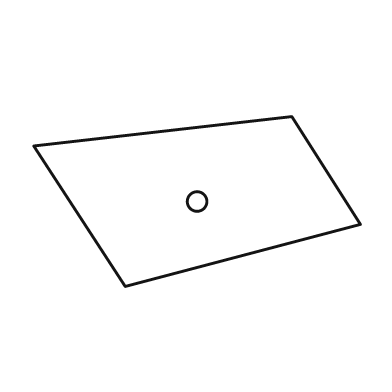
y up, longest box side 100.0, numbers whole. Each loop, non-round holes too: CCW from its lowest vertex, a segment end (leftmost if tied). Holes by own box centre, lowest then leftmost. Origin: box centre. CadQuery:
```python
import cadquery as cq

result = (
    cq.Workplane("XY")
    .moveTo(-22.0, -26.0)
    .lineTo(50.0, -7.0)
    .lineTo(29.0, 26.0)
    .lineTo(-50.0, 17.0)
    .close()
    .moveTo(0.0, 0.0)
    .circle(3.0)
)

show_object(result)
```